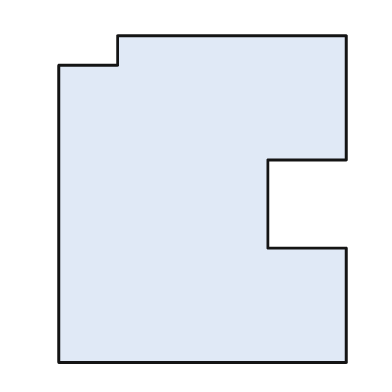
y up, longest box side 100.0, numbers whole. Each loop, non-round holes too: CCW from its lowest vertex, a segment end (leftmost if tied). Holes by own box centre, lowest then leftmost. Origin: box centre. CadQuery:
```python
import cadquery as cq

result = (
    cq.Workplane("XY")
    .moveTo(-44.0, -50.0)
    .lineTo(44.0, -50.0)
    .lineTo(44.0, -15.0)
    .lineTo(20.0, -15.0)
    .lineTo(20.0, 12.0)
    .lineTo(44.0, 12.0)
    .lineTo(44.0, 50.0)
    .lineTo(-26.0, 50.0)
    .lineTo(-26.0, 41.0)
    .lineTo(-44.0, 41.0)
    .close()
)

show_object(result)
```